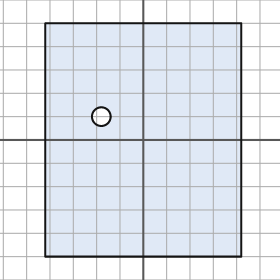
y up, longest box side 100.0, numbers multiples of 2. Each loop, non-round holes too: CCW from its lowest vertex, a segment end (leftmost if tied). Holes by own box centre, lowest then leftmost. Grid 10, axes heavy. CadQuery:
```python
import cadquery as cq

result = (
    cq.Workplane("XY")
    .moveTo(-42.0, -50.0)
    .lineTo(42.0, -50.0)
    .lineTo(42.0, 50.0)
    .lineTo(-42.0, 50.0)
    .close()
    .moveTo(-18.0, 10.0)
    .circle(4.0)
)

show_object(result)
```